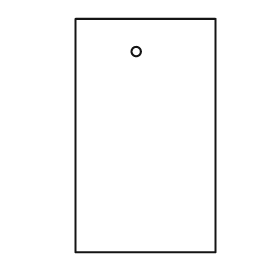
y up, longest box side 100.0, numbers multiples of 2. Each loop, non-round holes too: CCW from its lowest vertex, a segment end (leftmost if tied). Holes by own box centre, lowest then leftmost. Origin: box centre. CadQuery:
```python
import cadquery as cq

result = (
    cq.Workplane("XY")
    .moveTo(-30.0, -50.0)
    .lineTo(30.0, -50.0)
    .lineTo(30.0, 50.0)
    .lineTo(-30.0, 50.0)
    .close()
    .moveTo(-4.0, 36.0)
    .circle(2.0)
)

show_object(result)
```